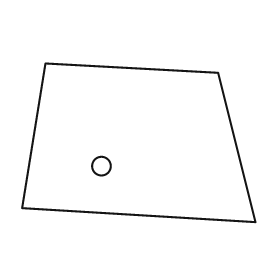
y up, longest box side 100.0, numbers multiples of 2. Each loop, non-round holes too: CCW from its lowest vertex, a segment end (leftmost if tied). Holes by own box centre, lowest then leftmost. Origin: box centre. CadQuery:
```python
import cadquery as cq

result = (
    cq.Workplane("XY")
    .moveTo(50.0, -34.0)
    .lineTo(34.0, 30.0)
    .lineTo(-40.0, 34.0)
    .lineTo(-50.0, -28.0)
    .close()
    .moveTo(-16.0, -10.0)
    .circle(4.0)
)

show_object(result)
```